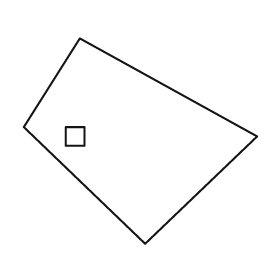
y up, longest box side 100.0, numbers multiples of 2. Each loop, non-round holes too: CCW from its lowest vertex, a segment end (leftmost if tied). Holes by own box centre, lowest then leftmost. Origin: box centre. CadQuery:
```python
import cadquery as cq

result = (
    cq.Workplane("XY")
    .moveTo(2.0, -44.0)
    .lineTo(50.0, 2.0)
    .lineTo(-26.0, 44.0)
    .lineTo(-50.0, 6.0)
    .close()
    .moveTo(-32.0, -2.0)
    .lineTo(-24.0, -2.0)
    .lineTo(-24.0, 6.0)
    .lineTo(-32.0, 6.0)
    .close()
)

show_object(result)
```